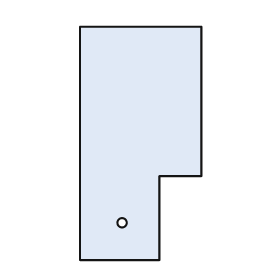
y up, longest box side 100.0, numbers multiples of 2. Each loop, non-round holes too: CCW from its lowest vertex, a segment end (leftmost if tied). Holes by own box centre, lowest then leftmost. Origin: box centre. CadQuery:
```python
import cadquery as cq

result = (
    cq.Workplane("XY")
    .moveTo(-26.0, -50.0)
    .lineTo(8.0, -50.0)
    .lineTo(8.0, -14.0)
    .lineTo(26.0, -14.0)
    .lineTo(26.0, 50.0)
    .lineTo(-26.0, 50.0)
    .close()
    .moveTo(-8.0, -34.0)
    .circle(2.0)
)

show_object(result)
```